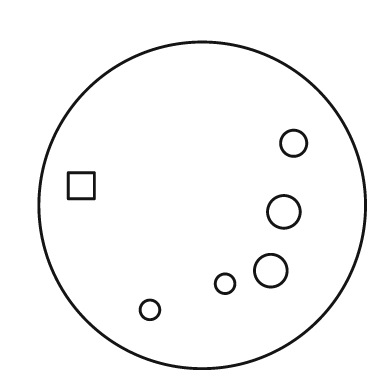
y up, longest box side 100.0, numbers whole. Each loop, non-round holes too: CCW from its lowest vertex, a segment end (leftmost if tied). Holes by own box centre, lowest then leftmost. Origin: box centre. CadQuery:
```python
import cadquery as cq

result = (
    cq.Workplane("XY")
    .moveTo(0.0, 0.0)
    .circle(50.0)
    .moveTo(-16.0, -32.0)
    .circle(3.0)
    .moveTo(7.0, -24.0)
    .circle(3.0)
    .moveTo(21.0, -20.0)
    .circle(5.0)
    .moveTo(25.0, -2.0)
    .circle(5.0)
    .moveTo(-41.0, 2.0)
    .lineTo(-33.0, 2.0)
    .lineTo(-33.0, 10.0)
    .lineTo(-41.0, 10.0)
    .close()
    .moveTo(28.0, 19.0)
    .circle(4.0)
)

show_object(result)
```